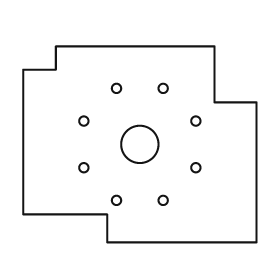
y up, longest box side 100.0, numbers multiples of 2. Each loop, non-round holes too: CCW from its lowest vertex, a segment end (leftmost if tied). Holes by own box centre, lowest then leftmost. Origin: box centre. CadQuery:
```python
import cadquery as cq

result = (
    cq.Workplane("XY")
    .moveTo(-14.0, -42.0)
    .lineTo(50.0, -42.0)
    .lineTo(50.0, 18.0)
    .lineTo(32.0, 18.0)
    .lineTo(32.0, 42.0)
    .lineTo(-36.0, 42.0)
    .lineTo(-36.0, 32.0)
    .lineTo(-50.0, 32.0)
    .lineTo(-50.0, -30.0)
    .lineTo(-14.0, -30.0)
    .close()
    .moveTo(-10.0, -24.0)
    .circle(2.0)
    .moveTo(10.0, -24.0)
    .circle(2.0)
    .moveTo(-24.0, -10.0)
    .circle(2.0)
    .moveTo(24.0, -10.0)
    .circle(2.0)
    .moveTo(0.0, 0.0)
    .circle(8.0)
    .moveTo(-24.0, 10.0)
    .circle(2.0)
    .moveTo(24.0, 10.0)
    .circle(2.0)
    .moveTo(-10.0, 24.0)
    .circle(2.0)
    .moveTo(10.0, 24.0)
    .circle(2.0)
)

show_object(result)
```